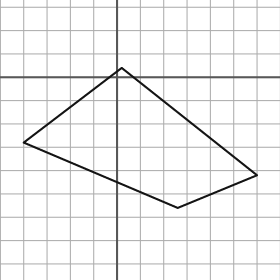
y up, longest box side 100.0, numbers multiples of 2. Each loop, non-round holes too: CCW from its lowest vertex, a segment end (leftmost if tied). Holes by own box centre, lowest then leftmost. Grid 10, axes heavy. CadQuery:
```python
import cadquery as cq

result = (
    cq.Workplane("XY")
    .moveTo(26.0, -56.0)
    .lineTo(60.0, -42.0)
    .lineTo(2.0, 4.0)
    .lineTo(-40.0, -28.0)
    .close()
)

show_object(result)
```